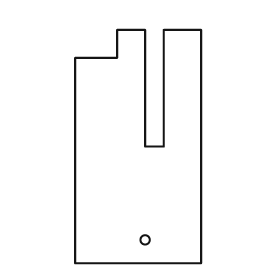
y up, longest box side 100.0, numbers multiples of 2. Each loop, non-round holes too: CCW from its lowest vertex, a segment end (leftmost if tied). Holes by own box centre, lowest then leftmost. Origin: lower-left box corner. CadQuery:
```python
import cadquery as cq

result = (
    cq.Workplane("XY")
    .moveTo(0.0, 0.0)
    .lineTo(54.0, 0.0)
    .lineTo(54.0, 100.0)
    .lineTo(38.0, 100.0)
    .lineTo(38.0, 50.0)
    .lineTo(30.0, 50.0)
    .lineTo(30.0, 100.0)
    .lineTo(18.0, 100.0)
    .lineTo(18.0, 88.0)
    .lineTo(0.0, 88.0)
    .close()
    .moveTo(30.0, 10.0)
    .circle(2.0)
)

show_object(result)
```